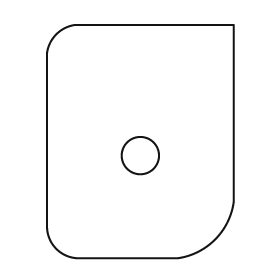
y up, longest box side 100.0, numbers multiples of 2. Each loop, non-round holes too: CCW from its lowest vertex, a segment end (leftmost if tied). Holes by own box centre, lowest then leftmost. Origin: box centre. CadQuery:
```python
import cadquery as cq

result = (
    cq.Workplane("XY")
    .moveTo(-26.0, -50.0)
    .lineTo(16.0, -50.0)
    .threePointArc((32.0, -42.0), (40.0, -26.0))
    .lineTo(40.0, 50.0)
    .lineTo(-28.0, 50.0)
    .threePointArc((-36.0, 46.0), (-40.0, 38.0))
    .lineTo(-40.0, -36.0)
    .threePointArc((-36.0, -46.0), (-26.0, -50.0))
    .close()
    .moveTo(0.0, -6.0)
    .circle(8.0)
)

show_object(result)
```